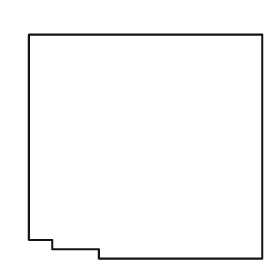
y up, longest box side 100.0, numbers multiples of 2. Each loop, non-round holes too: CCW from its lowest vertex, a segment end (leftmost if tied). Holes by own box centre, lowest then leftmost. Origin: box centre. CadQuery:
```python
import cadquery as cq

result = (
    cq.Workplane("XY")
    .moveTo(-20.0, -48.0)
    .lineTo(50.0, -48.0)
    .lineTo(50.0, 48.0)
    .lineTo(-50.0, 48.0)
    .lineTo(-50.0, -40.0)
    .lineTo(-40.0, -40.0)
    .lineTo(-40.0, -44.0)
    .lineTo(-20.0, -44.0)
    .close()
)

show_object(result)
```